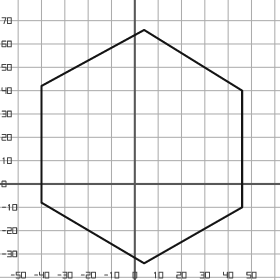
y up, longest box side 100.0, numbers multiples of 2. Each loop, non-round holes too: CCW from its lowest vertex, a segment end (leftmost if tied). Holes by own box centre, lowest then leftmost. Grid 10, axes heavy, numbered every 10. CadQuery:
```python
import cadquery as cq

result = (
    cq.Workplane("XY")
    .moveTo(4.0, -34.0)
    .lineTo(46.0, -10.0)
    .lineTo(46.0, 40.0)
    .lineTo(4.0, 66.0)
    .lineTo(-40.0, 42.0)
    .lineTo(-40.0, -8.0)
    .close()
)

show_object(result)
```